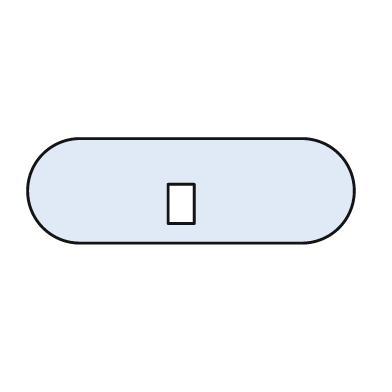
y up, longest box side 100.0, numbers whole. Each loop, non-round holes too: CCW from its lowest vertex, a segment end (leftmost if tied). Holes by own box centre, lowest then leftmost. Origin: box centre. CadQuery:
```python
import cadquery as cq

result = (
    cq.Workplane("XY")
    .moveTo(-34.0, -16.0)
    .lineTo(34.0, -16.0)
    .threePointArc((50.0, 0.0), (34.0, 16.0))
    .lineTo(-34.0, 16.0)
    .threePointArc((-50.0, 0.0), (-34.0, -16.0))
    .close()
    .moveTo(-7.0, -10.0)
    .lineTo(1.0, -10.0)
    .lineTo(1.0, 2.0)
    .lineTo(-7.0, 2.0)
    .close()
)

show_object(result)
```